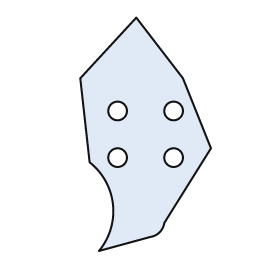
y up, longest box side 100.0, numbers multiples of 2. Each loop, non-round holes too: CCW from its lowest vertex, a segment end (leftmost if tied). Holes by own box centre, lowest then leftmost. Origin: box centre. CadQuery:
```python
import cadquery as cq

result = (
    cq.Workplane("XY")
    .moveTo(-20.0, -50.0)
    .lineTo(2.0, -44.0)
    .threePointArc((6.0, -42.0), (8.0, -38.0))
    .lineTo(28.0, -6.0)
    .lineTo(16.0, 24.0)
    .lineTo(-4.0, 50.0)
    .lineTo(-28.0, 24.0)
    .lineTo(-24.0, -12.0)
    .threePointArc((-14.0, -30.0), (-20.0, -50.0))
    .close()
    .moveTo(-12.0, -10.0)
    .circle(4.0)
    .moveTo(12.0, -10.0)
    .circle(4.0)
    .moveTo(-12.0, 10.0)
    .circle(4.0)
    .moveTo(12.0, 10.0)
    .circle(4.0)
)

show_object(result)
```